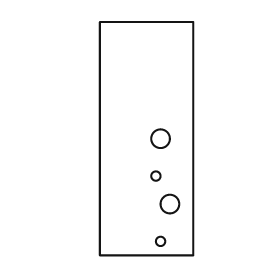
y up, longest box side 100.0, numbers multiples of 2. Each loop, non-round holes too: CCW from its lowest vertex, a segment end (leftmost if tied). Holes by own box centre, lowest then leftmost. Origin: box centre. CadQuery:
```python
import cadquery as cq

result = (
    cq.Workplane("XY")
    .moveTo(-20.0, -50.0)
    .lineTo(20.0, -50.0)
    .lineTo(20.0, 50.0)
    .lineTo(-20.0, 50.0)
    .close()
    .moveTo(6.0, -44.0)
    .circle(2.0)
    .moveTo(10.0, -28.0)
    .circle(4.0)
    .moveTo(4.0, -16.0)
    .circle(2.0)
    .moveTo(6.0, 0.0)
    .circle(4.0)
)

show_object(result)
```